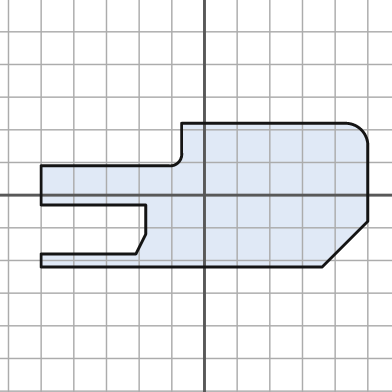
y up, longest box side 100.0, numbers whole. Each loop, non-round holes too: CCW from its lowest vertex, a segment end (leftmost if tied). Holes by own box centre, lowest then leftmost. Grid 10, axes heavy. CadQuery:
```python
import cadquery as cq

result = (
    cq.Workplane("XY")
    .moveTo(-50.0, -22.0)
    .lineTo(36.0, -22.0)
    .lineTo(50.0, -8.0)
    .lineTo(50.0, 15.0)
    .threePointArc((48.0, 20.0), (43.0, 22.0))
    .lineTo(-7.0, 22.0)
    .lineTo(-7.0, 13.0)
    .threePointArc((-8.0, 10.0), (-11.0, 9.0))
    .lineTo(-50.0, 9.0)
    .lineTo(-50.0, -3.0)
    .lineTo(-18.0, -3.0)
    .lineTo(-18.0, -12.0)
    .lineTo(-21.0, -18.0)
    .lineTo(-50.0, -18.0)
    .close()
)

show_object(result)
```